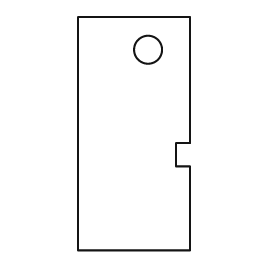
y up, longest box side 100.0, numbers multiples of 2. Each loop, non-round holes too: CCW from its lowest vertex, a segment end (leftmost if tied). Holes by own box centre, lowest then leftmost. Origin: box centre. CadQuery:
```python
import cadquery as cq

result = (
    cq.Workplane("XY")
    .moveTo(-24.0, -50.0)
    .lineTo(24.0, -50.0)
    .lineTo(24.0, -14.0)
    .lineTo(18.0, -14.0)
    .lineTo(18.0, -4.0)
    .lineTo(24.0, -4.0)
    .lineTo(24.0, 50.0)
    .lineTo(-24.0, 50.0)
    .close()
    .moveTo(6.0, 36.0)
    .circle(6.0)
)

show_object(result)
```